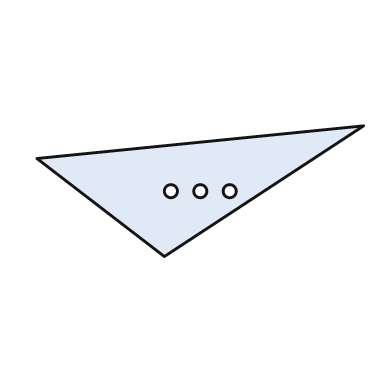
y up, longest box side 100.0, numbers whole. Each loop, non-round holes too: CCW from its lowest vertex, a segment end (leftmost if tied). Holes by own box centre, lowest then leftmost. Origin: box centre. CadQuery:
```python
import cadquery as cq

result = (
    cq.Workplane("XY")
    .moveTo(-11.0, -20.0)
    .lineTo(50.0, 20.0)
    .lineTo(-50.0, 10.0)
    .close()
    .moveTo(-9.0, 0.0)
    .circle(2.0)
    .moveTo(0.0, 0.0)
    .circle(2.0)
    .moveTo(9.0, 0.0)
    .circle(2.0)
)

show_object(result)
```